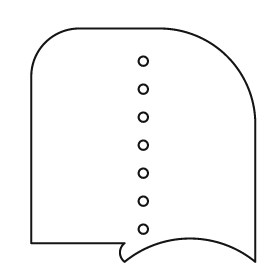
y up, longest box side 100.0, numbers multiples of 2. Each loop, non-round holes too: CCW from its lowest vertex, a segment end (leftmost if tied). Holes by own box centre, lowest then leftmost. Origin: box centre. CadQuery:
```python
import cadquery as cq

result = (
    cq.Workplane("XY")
    .moveTo(-8.0, -50.0)
    .threePointArc((20.0, -40.0), (48.0, -50.0))
    .lineTo(48.0, 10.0)
    .threePointArc((36.0, 38.0), (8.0, 50.0))
    .lineTo(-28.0, 50.0)
    .threePointArc((-42.0, 44.0), (-48.0, 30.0))
    .lineTo(-48.0, -42.0)
    .lineTo(-8.0, -42.0)
    .threePointArc((-10.0, -46.0), (-8.0, -50.0))
    .close()
    .moveTo(0.0, -36.0)
    .circle(2.0)
    .moveTo(0.0, -24.0)
    .circle(2.0)
    .moveTo(0.0, -12.0)
    .circle(2.0)
    .moveTo(0.0, 0.0)
    .circle(2.0)
    .moveTo(0.0, 12.0)
    .circle(2.0)
    .moveTo(0.0, 24.0)
    .circle(2.0)
    .moveTo(0.0, 36.0)
    .circle(2.0)
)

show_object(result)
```